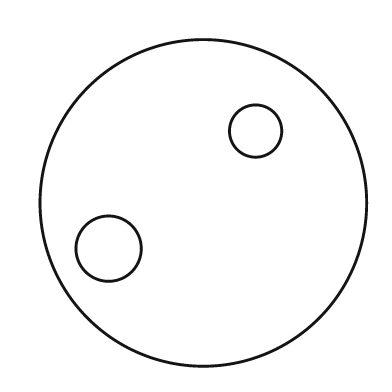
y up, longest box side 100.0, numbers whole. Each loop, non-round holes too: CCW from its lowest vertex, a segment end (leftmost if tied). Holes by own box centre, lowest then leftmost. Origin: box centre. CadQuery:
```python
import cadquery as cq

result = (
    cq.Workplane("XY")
    .moveTo(0.0, 0.0)
    .circle(50.0)
    .moveTo(-29.0, -14.0)
    .circle(10.0)
    .moveTo(16.0, 22.0)
    .circle(8.0)
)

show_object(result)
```